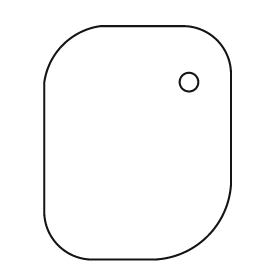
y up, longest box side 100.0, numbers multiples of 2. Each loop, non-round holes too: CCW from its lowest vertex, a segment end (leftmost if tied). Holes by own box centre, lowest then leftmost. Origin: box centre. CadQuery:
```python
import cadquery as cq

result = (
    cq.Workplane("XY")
    .moveTo(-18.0, -50.0)
    .lineTo(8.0, -50.0)
    .threePointArc((30.0, -40.0), (40.0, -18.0))
    .lineTo(40.0, 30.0)
    .threePointArc((34.0, 44.0), (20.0, 50.0))
    .lineTo(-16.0, 50.0)
    .threePointArc((-32.0, 42.0), (-40.0, 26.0))
    .lineTo(-40.0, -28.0)
    .threePointArc((-34.0, -44.0), (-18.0, -50.0))
    .close()
    .moveTo(22.0, 26.0)
    .circle(4.0)
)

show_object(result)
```